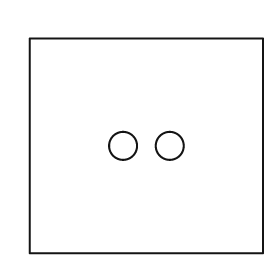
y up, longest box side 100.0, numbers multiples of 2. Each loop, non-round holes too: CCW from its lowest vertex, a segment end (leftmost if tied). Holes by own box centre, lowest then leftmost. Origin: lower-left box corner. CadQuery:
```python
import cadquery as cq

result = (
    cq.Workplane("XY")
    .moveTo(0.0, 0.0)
    .lineTo(100.0, 0.0)
    .lineTo(100.0, 92.0)
    .lineTo(0.0, 92.0)
    .close()
    .moveTo(40.0, 46.0)
    .circle(6.0)
    .moveTo(60.0, 46.0)
    .circle(6.0)
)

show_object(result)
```